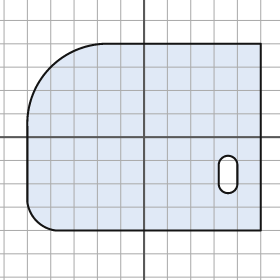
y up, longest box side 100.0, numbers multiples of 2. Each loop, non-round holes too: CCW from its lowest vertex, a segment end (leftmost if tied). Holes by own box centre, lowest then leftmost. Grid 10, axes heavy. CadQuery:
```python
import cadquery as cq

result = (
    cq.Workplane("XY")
    .moveTo(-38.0, -40.0)
    .lineTo(50.0, -40.0)
    .lineTo(50.0, 40.0)
    .lineTo(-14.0, 40.0)
    .threePointArc((-40.0, 30.0), (-50.0, 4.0))
    .lineTo(-50.0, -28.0)
    .threePointArc((-46.0, -36.0), (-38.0, -40.0))
    .close()
    .moveTo(32.0, -20.0)
    .threePointArc((36.0, -24.0), (40.0, -20.0))
    .lineTo(40.0, -12.0)
    .threePointArc((36.0, -8.0), (32.0, -12.0))
    .close()
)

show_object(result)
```